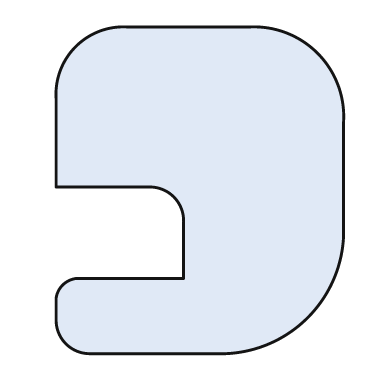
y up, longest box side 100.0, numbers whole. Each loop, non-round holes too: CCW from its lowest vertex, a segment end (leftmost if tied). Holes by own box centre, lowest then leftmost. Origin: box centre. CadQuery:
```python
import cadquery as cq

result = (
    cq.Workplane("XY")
    .moveTo(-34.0, -50.0)
    .lineTo(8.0, -50.0)
    .threePointArc((33.0, -39.0), (44.0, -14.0))
    .lineTo(44.0, 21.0)
    .threePointArc((36.0, 42.0), (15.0, 50.0))
    .lineTo(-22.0, 50.0)
    .threePointArc((-38.0, 44.0), (-44.0, 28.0))
    .lineTo(-44.0, 1.0)
    .lineTo(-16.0, 1.0)
    .threePointArc((-8.0, -2.0), (-5.0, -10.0))
    .lineTo(-5.0, -27.0)
    .lineTo(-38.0, -27.0)
    .threePointArc((-42.0, -29.0), (-44.0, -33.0))
    .lineTo(-44.0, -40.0)
    .threePointArc((-41.0, -47.0), (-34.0, -50.0))
    .close()
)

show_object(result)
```